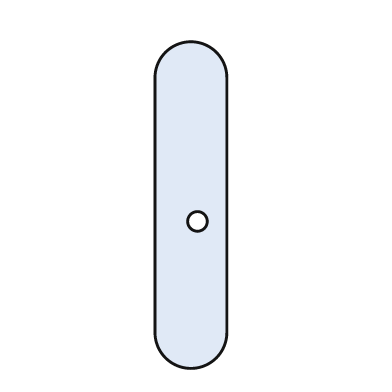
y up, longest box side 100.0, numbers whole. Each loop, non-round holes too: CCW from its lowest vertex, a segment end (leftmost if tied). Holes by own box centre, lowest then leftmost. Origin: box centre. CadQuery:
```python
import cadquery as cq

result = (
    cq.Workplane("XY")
    .moveTo(-11.0, -39.0)
    .threePointArc((0.0, -50.0), (11.0, -39.0))
    .lineTo(11.0, 39.0)
    .threePointArc((0.0, 50.0), (-11.0, 39.0))
    .close()
    .moveTo(2.0, -5.0)
    .circle(3.0)
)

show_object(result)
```